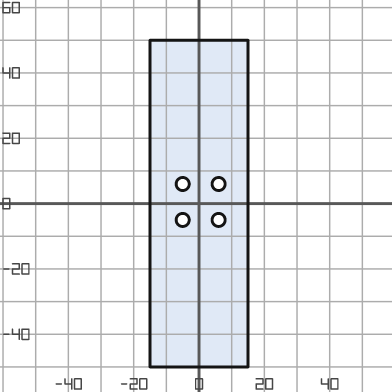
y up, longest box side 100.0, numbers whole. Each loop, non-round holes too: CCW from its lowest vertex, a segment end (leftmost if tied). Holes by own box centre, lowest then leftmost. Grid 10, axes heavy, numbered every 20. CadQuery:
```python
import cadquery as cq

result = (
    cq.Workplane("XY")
    .moveTo(-15.0, -50.0)
    .lineTo(15.0, -50.0)
    .lineTo(15.0, 50.0)
    .lineTo(-15.0, 50.0)
    .close()
    .moveTo(-5.0, -5.0)
    .circle(2.0)
    .moveTo(6.0, -5.0)
    .circle(2.0)
    .moveTo(-5.0, 6.0)
    .circle(2.0)
    .moveTo(6.0, 6.0)
    .circle(2.0)
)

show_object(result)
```